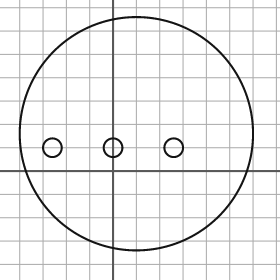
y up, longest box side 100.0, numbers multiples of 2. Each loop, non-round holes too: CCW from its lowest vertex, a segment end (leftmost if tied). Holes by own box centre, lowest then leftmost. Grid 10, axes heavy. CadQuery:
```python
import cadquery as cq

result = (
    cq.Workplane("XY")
    .moveTo(10.0, 16.0)
    .circle(50.0)
    .moveTo(-26.0, 10.0)
    .circle(4.0)
    .moveTo(0.0, 10.0)
    .circle(4.0)
    .moveTo(26.0, 10.0)
    .circle(4.0)
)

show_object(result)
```